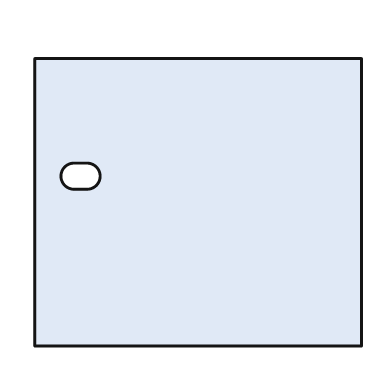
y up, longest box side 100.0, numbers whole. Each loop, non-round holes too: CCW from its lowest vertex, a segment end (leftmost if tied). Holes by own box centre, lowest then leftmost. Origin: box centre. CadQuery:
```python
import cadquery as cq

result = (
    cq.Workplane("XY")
    .moveTo(-50.0, -44.0)
    .lineTo(50.0, -44.0)
    .lineTo(50.0, 44.0)
    .lineTo(-50.0, 44.0)
    .close()
    .moveTo(-38.0, 4.0)
    .lineTo(-34.0, 4.0)
    .threePointArc((-30.0, 8.0), (-34.0, 12.0))
    .lineTo(-38.0, 12.0)
    .threePointArc((-42.0, 8.0), (-38.0, 4.0))
    .close()
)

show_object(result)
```